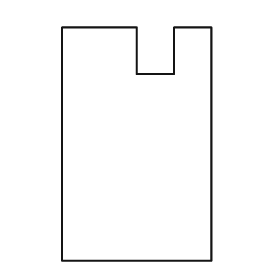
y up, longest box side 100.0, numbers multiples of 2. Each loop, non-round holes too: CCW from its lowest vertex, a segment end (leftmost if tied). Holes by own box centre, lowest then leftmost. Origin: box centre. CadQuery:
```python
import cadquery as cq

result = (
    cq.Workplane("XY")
    .moveTo(-32.0, -50.0)
    .lineTo(32.0, -50.0)
    .lineTo(32.0, 50.0)
    .lineTo(16.0, 50.0)
    .lineTo(16.0, 30.0)
    .lineTo(0.0, 30.0)
    .lineTo(0.0, 50.0)
    .lineTo(-32.0, 50.0)
    .close()
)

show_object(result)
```